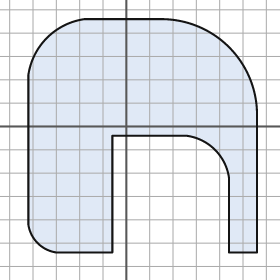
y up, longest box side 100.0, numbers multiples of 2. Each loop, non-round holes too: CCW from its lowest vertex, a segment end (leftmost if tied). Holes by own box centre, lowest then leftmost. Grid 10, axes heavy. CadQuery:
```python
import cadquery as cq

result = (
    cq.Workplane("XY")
    .moveTo(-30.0, -54.0)
    .lineTo(-6.0, -54.0)
    .lineTo(-6.0, -4.0)
    .lineTo(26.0, -4.0)
    .threePointArc((38.0, -10.0), (44.0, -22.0))
    .lineTo(44.0, -54.0)
    .lineTo(56.0, -54.0)
    .lineTo(56.0, 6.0)
    .threePointArc((44.0, 34.0), (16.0, 46.0))
    .lineTo(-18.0, 46.0)
    .threePointArc((-34.0, 38.0), (-42.0, 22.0))
    .lineTo(-42.0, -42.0)
    .threePointArc((-38.0, -50.0), (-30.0, -54.0))
    .close()
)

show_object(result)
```